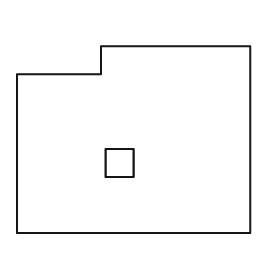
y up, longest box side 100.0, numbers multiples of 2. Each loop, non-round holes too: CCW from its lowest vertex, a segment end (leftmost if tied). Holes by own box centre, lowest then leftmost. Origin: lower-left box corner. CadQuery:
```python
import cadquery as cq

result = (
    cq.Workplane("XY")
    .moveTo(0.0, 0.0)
    .lineTo(100.0, 0.0)
    .lineTo(100.0, 80.0)
    .lineTo(36.0, 80.0)
    .lineTo(36.0, 68.0)
    .lineTo(0.0, 68.0)
    .close()
    .moveTo(38.0, 24.0)
    .lineTo(50.0, 24.0)
    .lineTo(50.0, 36.0)
    .lineTo(38.0, 36.0)
    .close()
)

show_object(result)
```